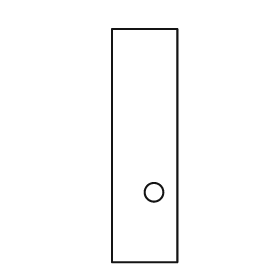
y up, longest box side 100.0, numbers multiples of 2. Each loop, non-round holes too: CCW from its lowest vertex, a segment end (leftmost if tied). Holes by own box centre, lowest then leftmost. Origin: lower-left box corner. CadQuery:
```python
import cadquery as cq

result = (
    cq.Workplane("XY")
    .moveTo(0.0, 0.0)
    .lineTo(28.0, 0.0)
    .lineTo(28.0, 100.0)
    .lineTo(0.0, 100.0)
    .close()
    .moveTo(18.0, 30.0)
    .circle(4.0)
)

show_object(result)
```